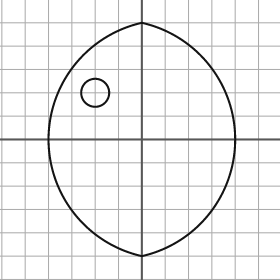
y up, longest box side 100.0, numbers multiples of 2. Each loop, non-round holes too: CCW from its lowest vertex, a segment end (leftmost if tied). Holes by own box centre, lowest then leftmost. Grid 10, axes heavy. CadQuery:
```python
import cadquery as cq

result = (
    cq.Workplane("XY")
    .moveTo(0.0, -50.0)
    .threePointArc((40.0, 0.0), (0.0, 50.0))
    .threePointArc((-40.0, 0.0), (0.0, -50.0))
    .close()
    .moveTo(-20.0, 20.0)
    .circle(6.0)
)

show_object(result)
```